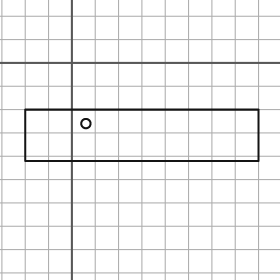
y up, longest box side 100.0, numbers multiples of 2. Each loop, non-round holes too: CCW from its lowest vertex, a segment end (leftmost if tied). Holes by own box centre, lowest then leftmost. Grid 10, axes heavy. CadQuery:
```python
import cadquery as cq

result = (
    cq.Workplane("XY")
    .moveTo(-20.0, -42.0)
    .lineTo(80.0, -42.0)
    .lineTo(80.0, -20.0)
    .lineTo(-20.0, -20.0)
    .close()
    .moveTo(6.0, -26.0)
    .circle(2.0)
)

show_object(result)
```